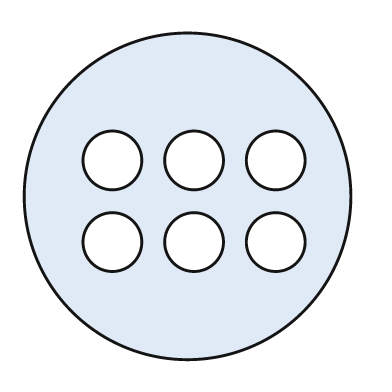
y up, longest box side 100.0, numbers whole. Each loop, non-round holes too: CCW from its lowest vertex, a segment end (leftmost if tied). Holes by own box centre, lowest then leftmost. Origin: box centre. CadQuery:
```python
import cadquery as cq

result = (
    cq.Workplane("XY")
    .moveTo(0.0, 0.0)
    .circle(50.0)
    .moveTo(-23.0, -14.0)
    .circle(9.0)
    .moveTo(2.0, -14.0)
    .circle(9.0)
    .moveTo(27.0, -14.0)
    .circle(9.0)
    .moveTo(-23.0, 11.0)
    .circle(9.0)
    .moveTo(2.0, 11.0)
    .circle(9.0)
    .moveTo(27.0, 11.0)
    .circle(9.0)
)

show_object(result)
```